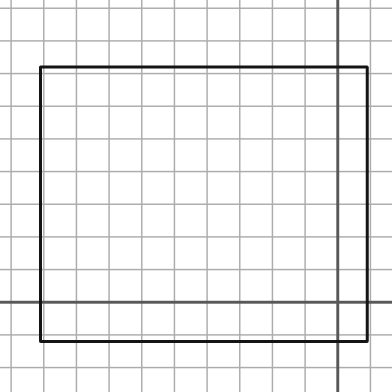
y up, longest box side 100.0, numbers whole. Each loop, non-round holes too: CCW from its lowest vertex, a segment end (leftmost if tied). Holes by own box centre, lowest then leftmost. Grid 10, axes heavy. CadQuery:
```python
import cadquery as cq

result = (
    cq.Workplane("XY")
    .moveTo(-91.0, -12.0)
    .lineTo(9.0, -12.0)
    .lineTo(9.0, 72.0)
    .lineTo(-91.0, 72.0)
    .close()
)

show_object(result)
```